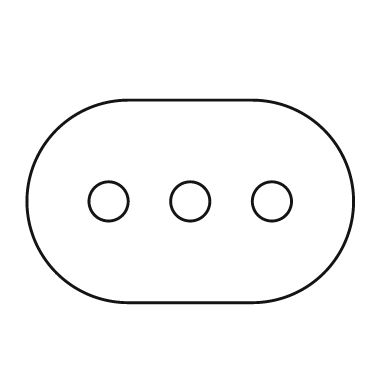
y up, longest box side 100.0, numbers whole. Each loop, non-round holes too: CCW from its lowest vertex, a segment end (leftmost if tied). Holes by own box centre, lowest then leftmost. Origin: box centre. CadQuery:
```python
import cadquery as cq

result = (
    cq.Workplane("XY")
    .moveTo(-19.0, -31.0)
    .lineTo(19.0, -31.0)
    .threePointArc((50.0, 0.0), (19.0, 31.0))
    .lineTo(-19.0, 31.0)
    .threePointArc((-50.0, 0.0), (-19.0, -31.0))
    .close()
    .moveTo(-25.0, 0.0)
    .circle(6.0)
    .moveTo(0.0, 0.0)
    .circle(6.0)
    .moveTo(25.0, 0.0)
    .circle(6.0)
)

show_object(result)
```